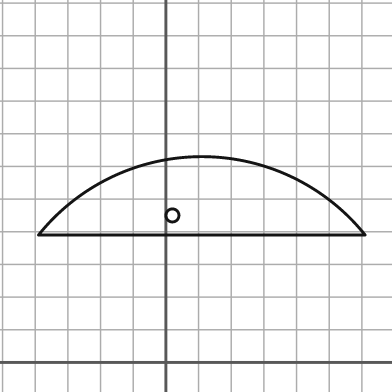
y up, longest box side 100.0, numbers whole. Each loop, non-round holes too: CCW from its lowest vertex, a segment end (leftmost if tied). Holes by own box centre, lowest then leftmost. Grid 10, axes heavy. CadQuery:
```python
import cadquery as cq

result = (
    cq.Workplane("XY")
    .moveTo(-39.0, 39.0)
    .lineTo(61.0, 39.0)
    .threePointArc((11.0, 63.0), (-39.0, 39.0))
    .close()
    .moveTo(2.0, 45.0)
    .circle(2.0)
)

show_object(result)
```